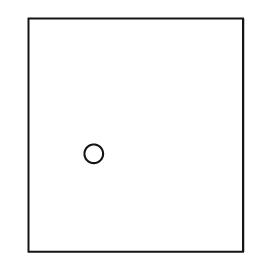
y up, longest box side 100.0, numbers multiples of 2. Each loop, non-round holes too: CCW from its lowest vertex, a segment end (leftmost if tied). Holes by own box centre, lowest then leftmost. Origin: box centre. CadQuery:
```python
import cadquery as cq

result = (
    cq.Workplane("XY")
    .moveTo(-46.0, -50.0)
    .lineTo(46.0, -50.0)
    .lineTo(46.0, 50.0)
    .lineTo(-46.0, 50.0)
    .close()
    .moveTo(-18.0, -8.0)
    .circle(4.0)
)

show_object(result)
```